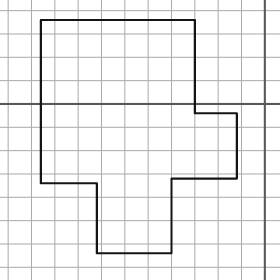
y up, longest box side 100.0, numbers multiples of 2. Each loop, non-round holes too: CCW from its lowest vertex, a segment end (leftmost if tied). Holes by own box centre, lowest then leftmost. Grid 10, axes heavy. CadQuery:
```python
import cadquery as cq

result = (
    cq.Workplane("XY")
    .moveTo(-72.0, -64.0)
    .lineTo(-40.0, -64.0)
    .lineTo(-40.0, -32.0)
    .lineTo(-12.0, -32.0)
    .lineTo(-12.0, -4.0)
    .lineTo(-30.0, -4.0)
    .lineTo(-30.0, 36.0)
    .lineTo(-96.0, 36.0)
    .lineTo(-96.0, -34.0)
    .lineTo(-72.0, -34.0)
    .close()
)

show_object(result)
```